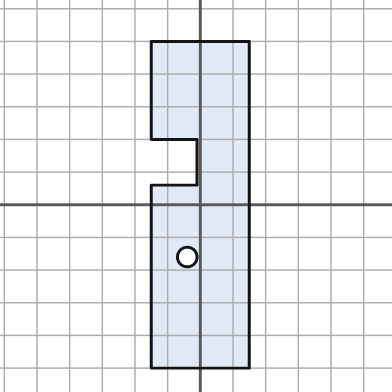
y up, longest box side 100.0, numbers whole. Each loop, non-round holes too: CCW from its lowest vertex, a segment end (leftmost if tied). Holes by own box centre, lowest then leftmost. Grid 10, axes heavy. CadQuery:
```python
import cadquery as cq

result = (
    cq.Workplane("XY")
    .moveTo(-15.0, -50.0)
    .lineTo(15.0, -50.0)
    .lineTo(15.0, 50.0)
    .lineTo(-15.0, 50.0)
    .lineTo(-15.0, 20.0)
    .lineTo(-1.0, 20.0)
    .lineTo(-1.0, 6.0)
    .lineTo(-15.0, 6.0)
    .close()
    .moveTo(-4.0, -16.0)
    .circle(3.0)
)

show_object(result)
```